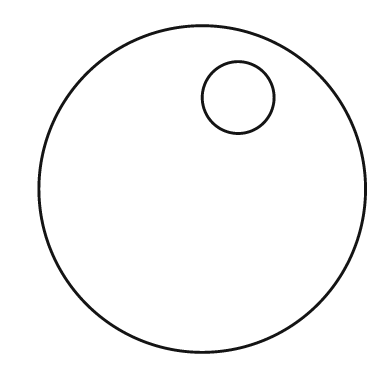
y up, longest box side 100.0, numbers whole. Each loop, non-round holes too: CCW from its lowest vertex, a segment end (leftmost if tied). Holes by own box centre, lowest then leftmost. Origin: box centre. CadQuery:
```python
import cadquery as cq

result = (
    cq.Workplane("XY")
    .moveTo(0.0, 0.0)
    .circle(50.0)
    .moveTo(11.0, 28.0)
    .circle(11.0)
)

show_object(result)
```